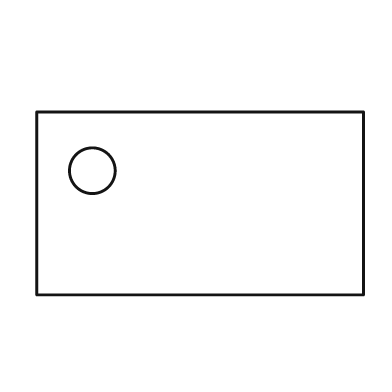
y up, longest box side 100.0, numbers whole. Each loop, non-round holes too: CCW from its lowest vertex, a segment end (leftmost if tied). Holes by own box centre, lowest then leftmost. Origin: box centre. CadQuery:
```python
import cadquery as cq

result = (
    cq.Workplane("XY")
    .moveTo(-50.0, -28.0)
    .lineTo(50.0, -28.0)
    .lineTo(50.0, 28.0)
    .lineTo(-50.0, 28.0)
    .close()
    .moveTo(-33.0, 10.0)
    .circle(7.0)
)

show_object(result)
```